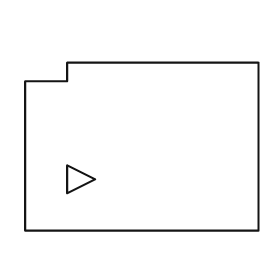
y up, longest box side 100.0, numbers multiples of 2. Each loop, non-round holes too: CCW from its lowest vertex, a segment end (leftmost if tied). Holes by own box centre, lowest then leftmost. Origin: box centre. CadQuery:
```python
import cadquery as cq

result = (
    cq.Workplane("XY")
    .moveTo(-50.0, -36.0)
    .lineTo(50.0, -36.0)
    .lineTo(50.0, 36.0)
    .lineTo(-32.0, 36.0)
    .lineTo(-32.0, 28.0)
    .lineTo(-50.0, 28.0)
    .close()
    .moveTo(-32.0, -20.0)
    .lineTo(-20.0, -14.0)
    .lineTo(-32.0, -8.0)
    .close()
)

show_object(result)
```